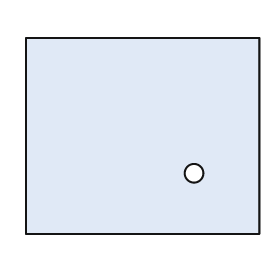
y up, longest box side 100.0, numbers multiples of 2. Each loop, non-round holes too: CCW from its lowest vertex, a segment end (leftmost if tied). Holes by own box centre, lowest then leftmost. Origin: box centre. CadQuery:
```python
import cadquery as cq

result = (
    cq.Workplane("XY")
    .moveTo(-50.0, -42.0)
    .lineTo(50.0, -42.0)
    .lineTo(50.0, 42.0)
    .lineTo(-50.0, 42.0)
    .close()
    .moveTo(22.0, -16.0)
    .circle(4.0)
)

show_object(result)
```